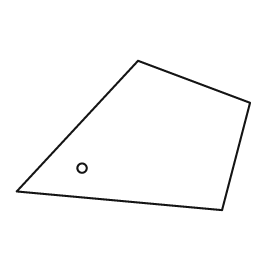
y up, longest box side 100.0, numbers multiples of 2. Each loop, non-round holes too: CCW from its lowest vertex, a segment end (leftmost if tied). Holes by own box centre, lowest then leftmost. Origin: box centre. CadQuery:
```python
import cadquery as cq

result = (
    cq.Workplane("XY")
    .moveTo(38.0, -32.0)
    .lineTo(50.0, 14.0)
    .lineTo(2.0, 32.0)
    .lineTo(-50.0, -24.0)
    .close()
    .moveTo(-22.0, -14.0)
    .circle(2.0)
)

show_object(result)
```